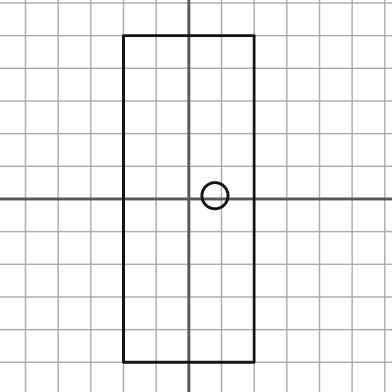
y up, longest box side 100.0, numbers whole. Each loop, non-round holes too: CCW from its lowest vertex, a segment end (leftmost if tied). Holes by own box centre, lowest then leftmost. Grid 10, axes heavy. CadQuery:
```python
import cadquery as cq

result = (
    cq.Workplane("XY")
    .moveTo(-20.0, -50.0)
    .lineTo(20.0, -50.0)
    .lineTo(20.0, 50.0)
    .lineTo(-20.0, 50.0)
    .close()
    .moveTo(8.0, 1.0)
    .circle(4.0)
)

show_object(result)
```